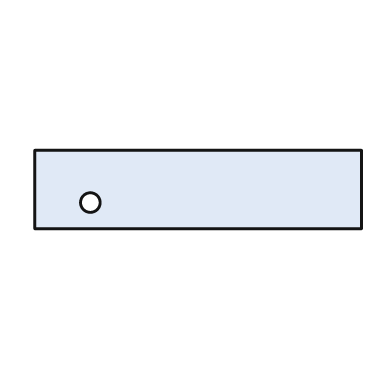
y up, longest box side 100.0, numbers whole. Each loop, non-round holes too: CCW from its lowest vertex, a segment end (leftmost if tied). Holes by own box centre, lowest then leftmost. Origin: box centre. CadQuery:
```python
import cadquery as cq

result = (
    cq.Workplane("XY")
    .moveTo(-50.0, -12.0)
    .lineTo(50.0, -12.0)
    .lineTo(50.0, 12.0)
    .lineTo(-50.0, 12.0)
    .close()
    .moveTo(-33.0, -4.0)
    .circle(3.0)
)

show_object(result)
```